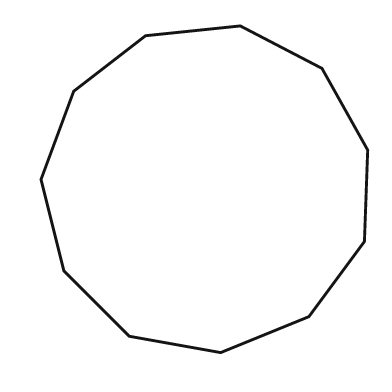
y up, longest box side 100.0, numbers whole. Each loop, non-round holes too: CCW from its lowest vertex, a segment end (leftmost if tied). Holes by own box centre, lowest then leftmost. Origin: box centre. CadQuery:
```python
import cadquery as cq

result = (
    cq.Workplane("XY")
    .moveTo(5.0, -50.0)
    .lineTo(32.0, -39.0)
    .lineTo(49.0, -16.0)
    .lineTo(50.0, 12.0)
    .lineTo(36.0, 37.0)
    .lineTo(11.0, 50.0)
    .lineTo(-18.0, 47.0)
    .lineTo(-40.0, 30.0)
    .lineTo(-50.0, 3.0)
    .lineTo(-43.0, -25.0)
    .lineTo(-23.0, -45.0)
    .close()
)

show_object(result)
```